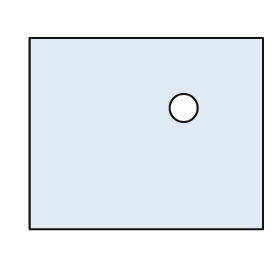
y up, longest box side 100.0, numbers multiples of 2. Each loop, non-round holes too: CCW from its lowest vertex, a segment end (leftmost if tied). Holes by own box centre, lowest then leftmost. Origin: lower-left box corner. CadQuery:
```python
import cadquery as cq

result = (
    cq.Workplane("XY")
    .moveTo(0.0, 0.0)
    .lineTo(100.0, 0.0)
    .lineTo(100.0, 82.0)
    .lineTo(0.0, 82.0)
    .close()
    .moveTo(66.0, 52.0)
    .circle(6.0)
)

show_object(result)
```